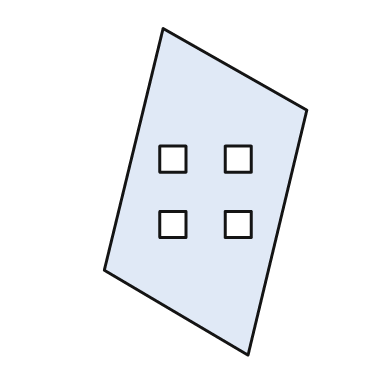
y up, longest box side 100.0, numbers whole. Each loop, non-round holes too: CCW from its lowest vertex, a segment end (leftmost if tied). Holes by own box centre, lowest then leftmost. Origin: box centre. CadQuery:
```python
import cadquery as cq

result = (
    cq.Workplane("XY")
    .moveTo(13.0, -50.0)
    .lineTo(31.0, 25.0)
    .lineTo(-13.0, 50.0)
    .lineTo(-31.0, -24.0)
    .close()
    .moveTo(-14.0, -14.0)
    .lineTo(-6.0, -14.0)
    .lineTo(-6.0, -6.0)
    .lineTo(-14.0, -6.0)
    .close()
    .moveTo(6.0, -14.0)
    .lineTo(14.0, -14.0)
    .lineTo(14.0, -6.0)
    .lineTo(6.0, -6.0)
    .close()
    .moveTo(-14.0, 6.0)
    .lineTo(-6.0, 6.0)
    .lineTo(-6.0, 14.0)
    .lineTo(-14.0, 14.0)
    .close()
    .moveTo(6.0, 6.0)
    .lineTo(14.0, 6.0)
    .lineTo(14.0, 14.0)
    .lineTo(6.0, 14.0)
    .close()
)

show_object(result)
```